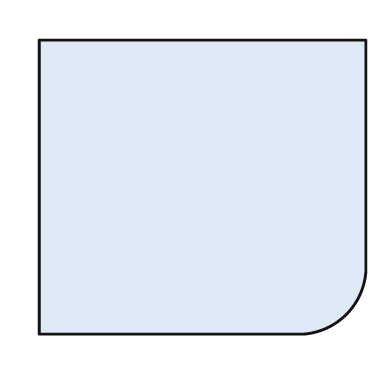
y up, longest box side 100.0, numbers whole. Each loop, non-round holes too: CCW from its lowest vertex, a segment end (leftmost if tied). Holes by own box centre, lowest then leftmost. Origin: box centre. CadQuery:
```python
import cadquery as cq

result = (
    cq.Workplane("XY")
    .moveTo(-50.0, -45.0)
    .lineTo(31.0, -45.0)
    .threePointArc((44.0, -39.0), (50.0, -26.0))
    .lineTo(50.0, 45.0)
    .lineTo(-50.0, 45.0)
    .close()
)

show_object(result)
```